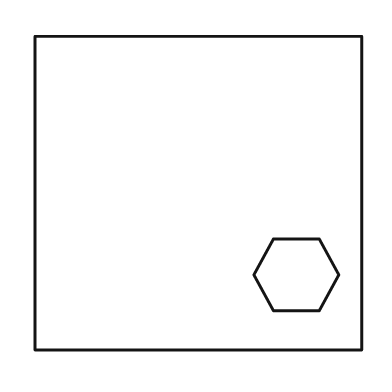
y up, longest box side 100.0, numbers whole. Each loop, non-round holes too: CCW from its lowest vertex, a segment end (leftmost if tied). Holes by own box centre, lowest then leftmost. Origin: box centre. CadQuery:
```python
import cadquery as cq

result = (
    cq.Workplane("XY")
    .moveTo(-50.0, -48.0)
    .lineTo(50.0, -48.0)
    .lineTo(50.0, 48.0)
    .lineTo(-50.0, 48.0)
    .close()
    .moveTo(23.0, -36.0)
    .lineTo(37.0, -36.0)
    .lineTo(43.0, -25.0)
    .lineTo(37.0, -14.0)
    .lineTo(23.0, -14.0)
    .lineTo(17.0, -25.0)
    .close()
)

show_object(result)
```